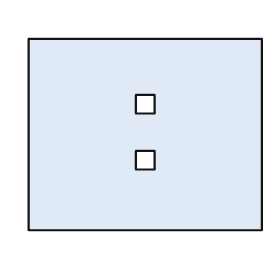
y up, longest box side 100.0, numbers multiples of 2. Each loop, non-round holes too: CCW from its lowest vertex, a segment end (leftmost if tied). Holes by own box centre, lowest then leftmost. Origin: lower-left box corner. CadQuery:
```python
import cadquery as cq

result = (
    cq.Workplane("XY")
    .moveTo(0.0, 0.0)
    .lineTo(100.0, 0.0)
    .lineTo(100.0, 82.0)
    .lineTo(0.0, 82.0)
    .close()
    .moveTo(46.0, 26.0)
    .lineTo(54.0, 26.0)
    .lineTo(54.0, 34.0)
    .lineTo(46.0, 34.0)
    .close()
    .moveTo(46.0, 50.0)
    .lineTo(54.0, 50.0)
    .lineTo(54.0, 58.0)
    .lineTo(46.0, 58.0)
    .close()
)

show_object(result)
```